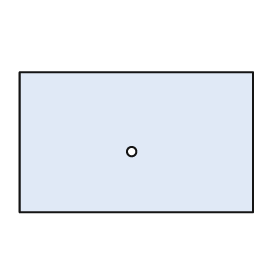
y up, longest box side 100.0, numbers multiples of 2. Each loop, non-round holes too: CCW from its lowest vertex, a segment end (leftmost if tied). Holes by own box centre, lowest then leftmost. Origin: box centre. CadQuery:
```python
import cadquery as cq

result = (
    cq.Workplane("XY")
    .moveTo(-50.0, -30.0)
    .lineTo(50.0, -30.0)
    .lineTo(50.0, 30.0)
    .lineTo(-50.0, 30.0)
    .close()
    .moveTo(-2.0, -4.0)
    .circle(2.0)
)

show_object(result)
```